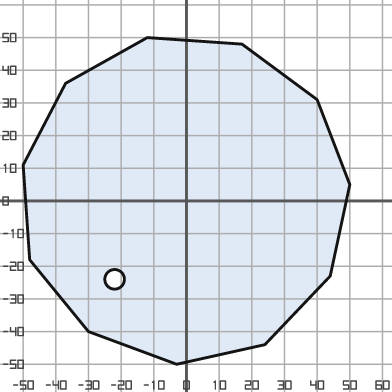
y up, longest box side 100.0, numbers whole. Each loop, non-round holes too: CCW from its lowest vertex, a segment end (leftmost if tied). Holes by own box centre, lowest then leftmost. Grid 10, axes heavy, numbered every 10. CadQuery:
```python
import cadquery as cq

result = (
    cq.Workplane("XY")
    .moveTo(-3.0, -50.0)
    .lineTo(24.0, -44.0)
    .lineTo(44.0, -23.0)
    .lineTo(50.0, 5.0)
    .lineTo(40.0, 31.0)
    .lineTo(17.0, 48.0)
    .lineTo(-12.0, 50.0)
    .lineTo(-37.0, 36.0)
    .lineTo(-50.0, 11.0)
    .lineTo(-48.0, -18.0)
    .lineTo(-30.0, -40.0)
    .close()
    .moveTo(-22.0, -24.0)
    .circle(3.0)
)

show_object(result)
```